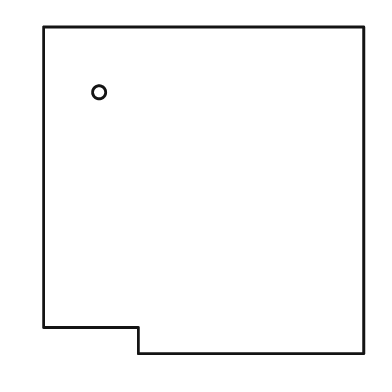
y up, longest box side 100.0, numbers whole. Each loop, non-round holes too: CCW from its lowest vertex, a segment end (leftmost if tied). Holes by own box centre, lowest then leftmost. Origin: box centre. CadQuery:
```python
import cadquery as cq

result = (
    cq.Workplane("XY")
    .moveTo(-20.0, -50.0)
    .lineTo(49.0, -50.0)
    .lineTo(49.0, 50.0)
    .lineTo(-49.0, 50.0)
    .lineTo(-49.0, -42.0)
    .lineTo(-20.0, -42.0)
    .close()
    .moveTo(-32.0, 30.0)
    .circle(2.0)
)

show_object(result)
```